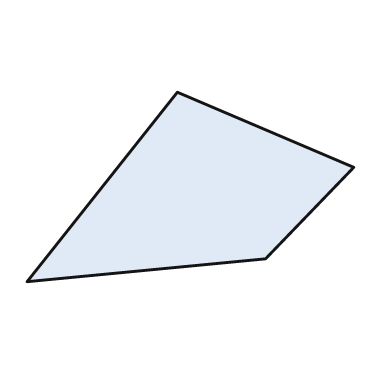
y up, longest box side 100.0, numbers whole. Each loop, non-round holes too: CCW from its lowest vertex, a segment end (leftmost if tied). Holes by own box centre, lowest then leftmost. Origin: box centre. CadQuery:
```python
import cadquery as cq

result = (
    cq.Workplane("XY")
    .moveTo(-50.0, -29.0)
    .lineTo(23.0, -22.0)
    .lineTo(50.0, 6.0)
    .lineTo(-4.0, 29.0)
    .close()
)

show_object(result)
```